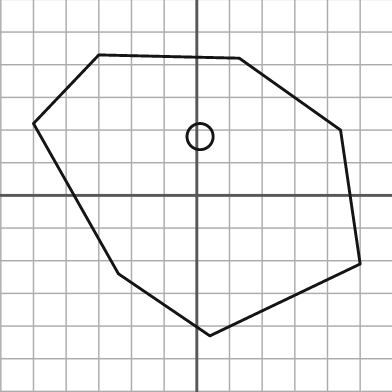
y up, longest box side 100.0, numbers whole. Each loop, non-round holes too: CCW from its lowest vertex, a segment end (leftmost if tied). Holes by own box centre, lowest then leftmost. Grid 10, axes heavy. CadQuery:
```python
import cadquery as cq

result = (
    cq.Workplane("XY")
    .moveTo(4.0, -43.0)
    .lineTo(50.0, -21.0)
    .lineTo(44.0, 20.0)
    .lineTo(13.0, 42.0)
    .lineTo(-30.0, 43.0)
    .lineTo(-50.0, 22.0)
    .lineTo(-24.0, -24.0)
    .close()
    .moveTo(1.0, 18.0)
    .circle(4.0)
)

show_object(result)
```